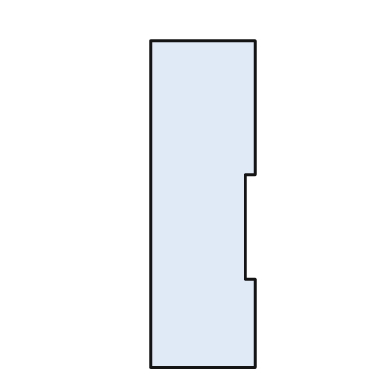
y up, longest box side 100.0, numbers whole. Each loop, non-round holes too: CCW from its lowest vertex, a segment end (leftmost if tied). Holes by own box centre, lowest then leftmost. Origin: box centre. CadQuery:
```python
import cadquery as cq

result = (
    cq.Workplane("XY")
    .moveTo(-16.0, -50.0)
    .lineTo(16.0, -50.0)
    .lineTo(16.0, -23.0)
    .lineTo(13.0, -23.0)
    .lineTo(13.0, 9.0)
    .lineTo(16.0, 9.0)
    .lineTo(16.0, 50.0)
    .lineTo(-16.0, 50.0)
    .close()
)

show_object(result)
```